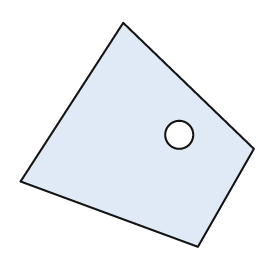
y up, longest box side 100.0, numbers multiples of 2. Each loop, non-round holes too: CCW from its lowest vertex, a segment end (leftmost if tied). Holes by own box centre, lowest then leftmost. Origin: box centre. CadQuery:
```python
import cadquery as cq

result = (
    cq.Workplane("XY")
    .moveTo(26.0, -48.0)
    .lineTo(50.0, -6.0)
    .lineTo(-6.0, 48.0)
    .lineTo(-50.0, -20.0)
    .close()
    .moveTo(18.0, 0.0)
    .circle(6.0)
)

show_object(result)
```